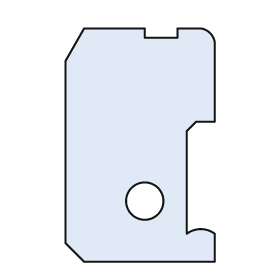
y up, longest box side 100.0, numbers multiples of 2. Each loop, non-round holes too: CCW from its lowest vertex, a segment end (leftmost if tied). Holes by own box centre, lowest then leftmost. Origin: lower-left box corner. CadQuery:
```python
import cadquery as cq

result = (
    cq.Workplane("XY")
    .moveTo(8.0, 0.0)
    .lineTo(64.0, 0.0)
    .lineTo(64.0, 12.0)
    .threePointArc((58.0, 14.0), (52.0, 12.0))
    .lineTo(52.0, 56.0)
    .lineTo(56.0, 60.0)
    .lineTo(64.0, 60.0)
    .lineTo(64.0, 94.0)
    .threePointArc((62.0, 98.0), (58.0, 100.0))
    .lineTo(48.0, 100.0)
    .lineTo(48.0, 96.0)
    .lineTo(34.0, 96.0)
    .lineTo(34.0, 100.0)
    .lineTo(8.0, 100.0)
    .lineTo(0.0, 86.0)
    .lineTo(0.0, 8.0)
    .close()
    .moveTo(34.0, 26.0)
    .circle(8.0)
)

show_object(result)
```